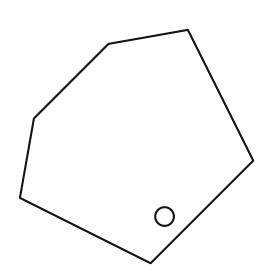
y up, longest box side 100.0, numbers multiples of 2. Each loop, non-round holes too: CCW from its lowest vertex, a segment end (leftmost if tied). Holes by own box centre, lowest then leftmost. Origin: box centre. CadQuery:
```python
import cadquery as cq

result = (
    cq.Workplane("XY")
    .moveTo(6.0, -50.0)
    .lineTo(50.0, -6.0)
    .lineTo(22.0, 50.0)
    .lineTo(-12.0, 44.0)
    .lineTo(-44.0, 12.0)
    .lineTo(-50.0, -22.0)
    .close()
    .moveTo(12.0, -30.0)
    .circle(4.0)
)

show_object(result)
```